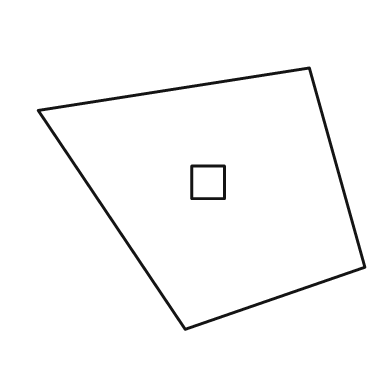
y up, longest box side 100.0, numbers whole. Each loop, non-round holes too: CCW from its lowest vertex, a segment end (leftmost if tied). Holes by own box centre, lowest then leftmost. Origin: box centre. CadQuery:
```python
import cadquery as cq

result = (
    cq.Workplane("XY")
    .moveTo(-5.0, -40.0)
    .lineTo(50.0, -21.0)
    .lineTo(33.0, 40.0)
    .lineTo(-50.0, 27.0)
    .close()
    .moveTo(-3.0, 0.0)
    .lineTo(7.0, 0.0)
    .lineTo(7.0, 10.0)
    .lineTo(-3.0, 10.0)
    .close()
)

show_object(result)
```